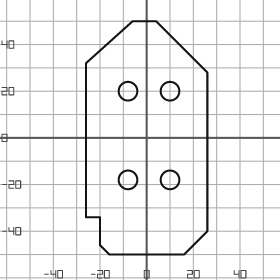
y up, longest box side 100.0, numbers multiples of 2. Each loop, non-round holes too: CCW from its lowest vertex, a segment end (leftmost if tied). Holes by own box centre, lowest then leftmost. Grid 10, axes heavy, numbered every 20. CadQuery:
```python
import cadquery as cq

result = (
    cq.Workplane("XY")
    .moveTo(-16.0, -50.0)
    .lineTo(16.0, -50.0)
    .lineTo(26.0, -40.0)
    .lineTo(26.0, 28.0)
    .lineTo(4.0, 50.0)
    .lineTo(-6.0, 50.0)
    .lineTo(-26.0, 32.0)
    .lineTo(-26.0, -34.0)
    .lineTo(-20.0, -34.0)
    .lineTo(-20.0, -46.0)
    .close()
    .moveTo(-8.0, -18.0)
    .circle(4.0)
    .moveTo(10.0, -18.0)
    .circle(4.0)
    .moveTo(-8.0, 20.0)
    .circle(4.0)
    .moveTo(10.0, 20.0)
    .circle(4.0)
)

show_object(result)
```